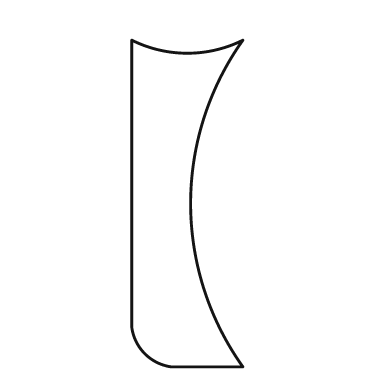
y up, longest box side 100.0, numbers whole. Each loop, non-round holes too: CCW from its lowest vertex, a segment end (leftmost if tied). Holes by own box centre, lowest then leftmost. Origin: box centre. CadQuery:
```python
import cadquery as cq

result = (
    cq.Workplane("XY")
    .moveTo(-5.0, -50.0)
    .lineTo(17.0, -50.0)
    .threePointArc((1.0, 0.0), (17.0, 50.0))
    .threePointArc((0.0, 46.0), (-17.0, 50.0))
    .lineTo(-17.0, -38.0)
    .threePointArc((-13.0, -46.0), (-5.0, -50.0))
    .close()
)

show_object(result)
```